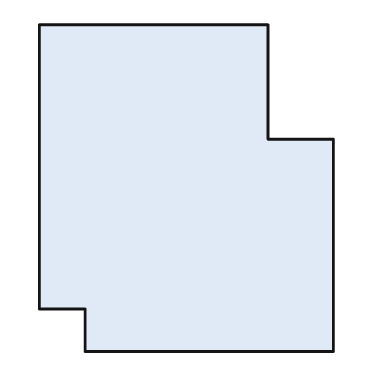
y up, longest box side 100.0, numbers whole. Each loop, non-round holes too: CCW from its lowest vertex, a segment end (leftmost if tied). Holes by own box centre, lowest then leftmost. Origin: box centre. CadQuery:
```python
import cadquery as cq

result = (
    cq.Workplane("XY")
    .moveTo(-31.0, -50.0)
    .lineTo(45.0, -50.0)
    .lineTo(45.0, 15.0)
    .lineTo(25.0, 15.0)
    .lineTo(25.0, 50.0)
    .lineTo(-45.0, 50.0)
    .lineTo(-45.0, -37.0)
    .lineTo(-31.0, -37.0)
    .close()
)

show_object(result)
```